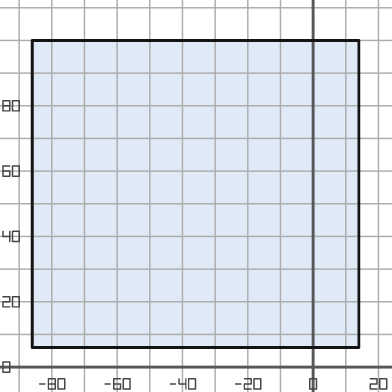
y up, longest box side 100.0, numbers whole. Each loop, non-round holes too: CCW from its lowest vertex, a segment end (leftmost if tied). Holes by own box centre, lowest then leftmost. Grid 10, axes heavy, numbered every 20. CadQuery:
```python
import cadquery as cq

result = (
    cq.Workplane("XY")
    .moveTo(-86.0, 6.0)
    .lineTo(14.0, 6.0)
    .lineTo(14.0, 100.0)
    .lineTo(-86.0, 100.0)
    .close()
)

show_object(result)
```